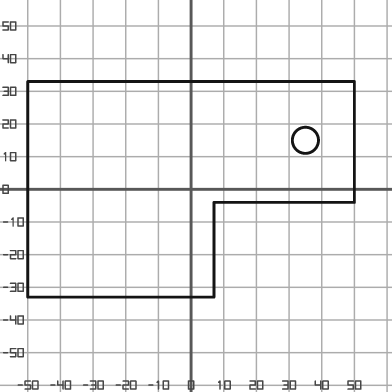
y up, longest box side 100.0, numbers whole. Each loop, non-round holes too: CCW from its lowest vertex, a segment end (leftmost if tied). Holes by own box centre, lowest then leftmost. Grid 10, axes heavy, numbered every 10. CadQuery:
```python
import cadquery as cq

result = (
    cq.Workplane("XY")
    .moveTo(-50.0, -33.0)
    .lineTo(7.0, -33.0)
    .lineTo(7.0, -4.0)
    .lineTo(50.0, -4.0)
    .lineTo(50.0, 33.0)
    .lineTo(-50.0, 33.0)
    .close()
    .moveTo(35.0, 15.0)
    .circle(4.0)
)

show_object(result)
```